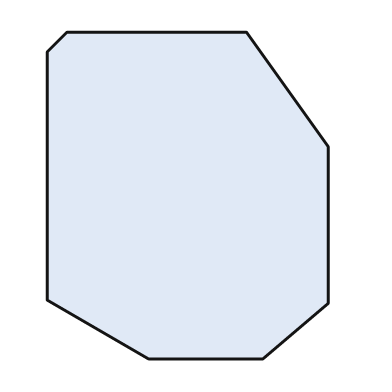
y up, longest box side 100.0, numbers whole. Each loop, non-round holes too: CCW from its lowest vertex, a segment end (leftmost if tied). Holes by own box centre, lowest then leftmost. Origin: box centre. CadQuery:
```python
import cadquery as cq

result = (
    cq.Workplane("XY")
    .moveTo(-12.0, -50.0)
    .lineTo(23.0, -50.0)
    .lineTo(43.0, -33.0)
    .lineTo(43.0, 15.0)
    .lineTo(18.0, 50.0)
    .lineTo(-37.0, 50.0)
    .lineTo(-43.0, 44.0)
    .lineTo(-43.0, -32.0)
    .close()
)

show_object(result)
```